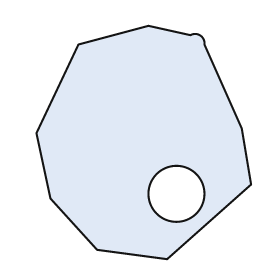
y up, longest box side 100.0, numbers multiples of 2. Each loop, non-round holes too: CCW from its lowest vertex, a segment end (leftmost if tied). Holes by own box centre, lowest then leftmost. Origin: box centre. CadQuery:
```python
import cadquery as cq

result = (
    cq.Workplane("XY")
    .moveTo(10.0, -50.0)
    .lineTo(46.0, -18.0)
    .lineTo(42.0, 6.0)
    .lineTo(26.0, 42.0)
    .threePointArc((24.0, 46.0), (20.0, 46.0))
    .lineTo(2.0, 50.0)
    .lineTo(-28.0, 42.0)
    .lineTo(-46.0, 4.0)
    .lineTo(-40.0, -24.0)
    .lineTo(-20.0, -46.0)
    .close()
    .moveTo(14.0, -22.0)
    .circle(12.0)
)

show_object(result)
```